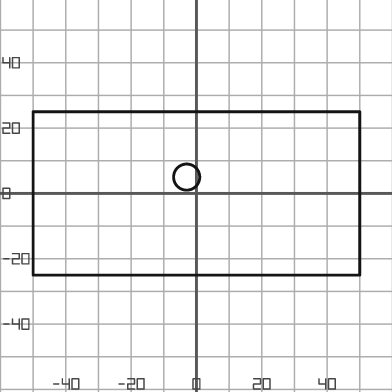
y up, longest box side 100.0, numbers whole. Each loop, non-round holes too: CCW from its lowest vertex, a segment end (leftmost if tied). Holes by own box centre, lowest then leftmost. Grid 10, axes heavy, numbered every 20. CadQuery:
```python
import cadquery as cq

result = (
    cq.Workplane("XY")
    .moveTo(-50.0, -25.0)
    .lineTo(50.0, -25.0)
    .lineTo(50.0, 25.0)
    .lineTo(-50.0, 25.0)
    .close()
    .moveTo(-3.0, 5.0)
    .circle(4.0)
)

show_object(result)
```